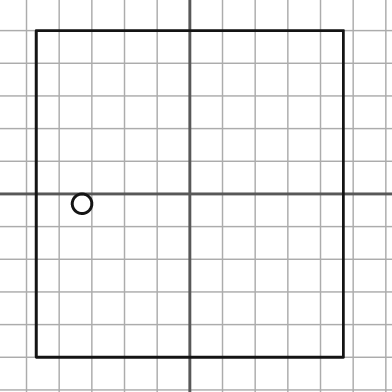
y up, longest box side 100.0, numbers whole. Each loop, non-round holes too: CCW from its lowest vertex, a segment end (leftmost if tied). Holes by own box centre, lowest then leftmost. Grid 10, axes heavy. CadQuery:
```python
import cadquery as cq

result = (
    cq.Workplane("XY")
    .moveTo(-47.0, -50.0)
    .lineTo(47.0, -50.0)
    .lineTo(47.0, 50.0)
    .lineTo(-47.0, 50.0)
    .close()
    .moveTo(-33.0, -3.0)
    .circle(3.0)
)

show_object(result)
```